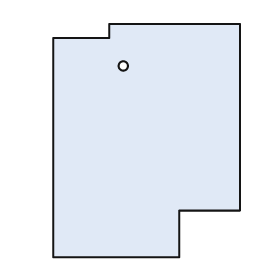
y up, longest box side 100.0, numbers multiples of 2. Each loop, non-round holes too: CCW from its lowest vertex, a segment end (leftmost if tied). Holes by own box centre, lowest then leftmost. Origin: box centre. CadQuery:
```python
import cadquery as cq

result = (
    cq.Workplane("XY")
    .moveTo(-40.0, -50.0)
    .lineTo(14.0, -50.0)
    .lineTo(14.0, -30.0)
    .lineTo(40.0, -30.0)
    .lineTo(40.0, 50.0)
    .lineTo(-16.0, 50.0)
    .lineTo(-16.0, 44.0)
    .lineTo(-40.0, 44.0)
    .close()
    .moveTo(-10.0, 32.0)
    .circle(2.0)
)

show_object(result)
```